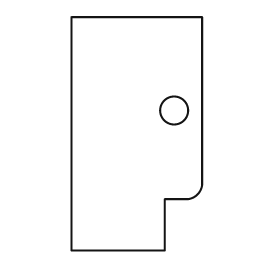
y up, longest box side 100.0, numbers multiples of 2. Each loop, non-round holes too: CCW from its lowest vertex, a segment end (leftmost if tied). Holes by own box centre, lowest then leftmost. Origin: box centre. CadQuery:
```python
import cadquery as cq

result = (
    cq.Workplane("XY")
    .moveTo(-28.0, -50.0)
    .lineTo(12.0, -50.0)
    .lineTo(12.0, -28.0)
    .lineTo(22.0, -28.0)
    .threePointArc((26.0, -26.0), (28.0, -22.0))
    .lineTo(28.0, 50.0)
    .lineTo(-28.0, 50.0)
    .close()
    .moveTo(16.0, 10.0)
    .circle(6.0)
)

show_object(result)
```